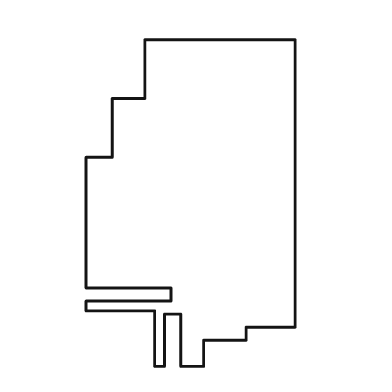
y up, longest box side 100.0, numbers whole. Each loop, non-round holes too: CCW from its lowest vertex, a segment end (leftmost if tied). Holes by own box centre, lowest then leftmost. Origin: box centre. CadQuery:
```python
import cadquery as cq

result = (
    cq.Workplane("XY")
    .moveTo(-11.0, -50.0)
    .lineTo(-8.0, -50.0)
    .lineTo(-8.0, -34.0)
    .lineTo(-3.0, -34.0)
    .lineTo(-3.0, -50.0)
    .lineTo(4.0, -50.0)
    .lineTo(4.0, -42.0)
    .lineTo(17.0, -42.0)
    .lineTo(17.0, -38.0)
    .lineTo(32.0, -38.0)
    .lineTo(32.0, 50.0)
    .lineTo(-14.0, 50.0)
    .lineTo(-14.0, 32.0)
    .lineTo(-24.0, 32.0)
    .lineTo(-24.0, 14.0)
    .lineTo(-32.0, 14.0)
    .lineTo(-32.0, -26.0)
    .lineTo(-6.0, -26.0)
    .lineTo(-6.0, -30.0)
    .lineTo(-32.0, -30.0)
    .lineTo(-32.0, -33.0)
    .lineTo(-11.0, -33.0)
    .close()
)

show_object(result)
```